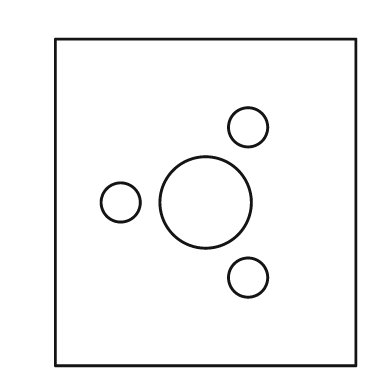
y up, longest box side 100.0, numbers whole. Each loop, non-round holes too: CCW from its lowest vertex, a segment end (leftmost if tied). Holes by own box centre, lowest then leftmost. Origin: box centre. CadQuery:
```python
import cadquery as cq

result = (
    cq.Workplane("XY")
    .moveTo(-46.0, -50.0)
    .lineTo(46.0, -50.0)
    .lineTo(46.0, 50.0)
    .lineTo(-46.0, 50.0)
    .close()
    .moveTo(13.0, -23.0)
    .circle(6.0)
    .moveTo(-26.0, 0.0)
    .circle(6.0)
    .moveTo(0.0, 0.0)
    .circle(14.0)
    .moveTo(13.0, 23.0)
    .circle(6.0)
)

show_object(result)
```